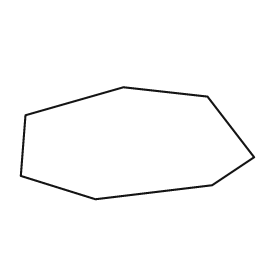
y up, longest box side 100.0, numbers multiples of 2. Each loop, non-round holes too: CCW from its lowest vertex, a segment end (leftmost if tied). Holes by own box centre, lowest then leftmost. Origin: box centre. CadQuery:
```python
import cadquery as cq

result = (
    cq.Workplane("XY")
    .moveTo(-18.0, -24.0)
    .lineTo(32.0, -18.0)
    .lineTo(50.0, -6.0)
    .lineTo(30.0, 20.0)
    .lineTo(-6.0, 24.0)
    .lineTo(-48.0, 12.0)
    .lineTo(-50.0, -14.0)
    .close()
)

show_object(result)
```